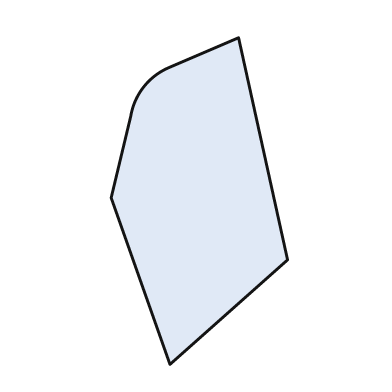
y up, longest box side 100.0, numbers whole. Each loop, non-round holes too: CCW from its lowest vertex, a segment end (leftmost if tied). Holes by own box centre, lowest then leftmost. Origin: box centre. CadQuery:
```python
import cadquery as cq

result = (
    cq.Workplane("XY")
    .moveTo(-9.0, -50.0)
    .lineTo(27.0, -18.0)
    .lineTo(12.0, 50.0)
    .lineTo(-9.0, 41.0)
    .threePointArc((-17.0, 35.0), (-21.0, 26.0))
    .lineTo(-27.0, 1.0)
    .close()
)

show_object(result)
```